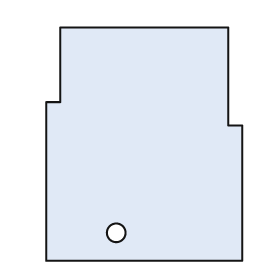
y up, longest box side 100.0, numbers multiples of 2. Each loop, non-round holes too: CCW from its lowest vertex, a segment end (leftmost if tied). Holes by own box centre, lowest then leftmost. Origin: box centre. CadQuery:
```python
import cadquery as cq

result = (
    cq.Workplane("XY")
    .moveTo(-42.0, -50.0)
    .lineTo(42.0, -50.0)
    .lineTo(42.0, 8.0)
    .lineTo(36.0, 8.0)
    .lineTo(36.0, 50.0)
    .lineTo(-36.0, 50.0)
    .lineTo(-36.0, 18.0)
    .lineTo(-42.0, 18.0)
    .close()
    .moveTo(-12.0, -38.0)
    .circle(4.0)
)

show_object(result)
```